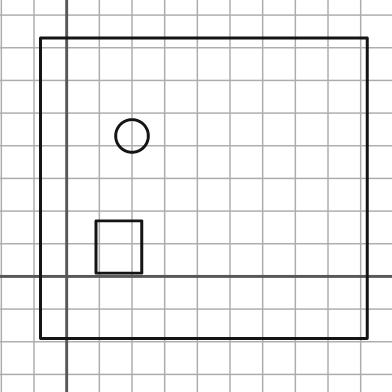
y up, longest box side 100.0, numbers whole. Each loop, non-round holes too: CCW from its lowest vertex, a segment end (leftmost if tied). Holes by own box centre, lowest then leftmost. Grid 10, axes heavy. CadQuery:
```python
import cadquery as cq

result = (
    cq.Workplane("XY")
    .moveTo(-8.0, -19.0)
    .lineTo(92.0, -19.0)
    .lineTo(92.0, 73.0)
    .lineTo(-8.0, 73.0)
    .close()
    .moveTo(9.0, 1.0)
    .lineTo(23.0, 1.0)
    .lineTo(23.0, 17.0)
    .lineTo(9.0, 17.0)
    .close()
    .moveTo(20.0, 43.0)
    .circle(5.0)
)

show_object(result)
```